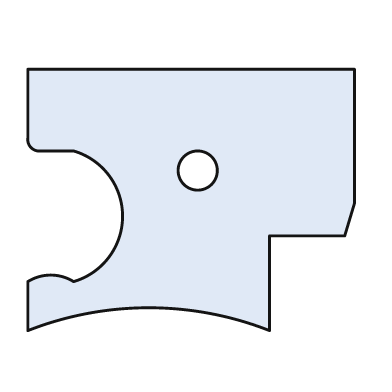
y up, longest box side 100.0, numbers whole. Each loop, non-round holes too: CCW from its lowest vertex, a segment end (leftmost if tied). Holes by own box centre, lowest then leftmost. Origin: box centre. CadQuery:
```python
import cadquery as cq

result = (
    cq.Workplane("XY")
    .moveTo(-50.0, -40.0)
    .threePointArc((-13.0, -33.0), (24.0, -40.0))
    .lineTo(24.0, -11.0)
    .lineTo(47.0, -11.0)
    .lineTo(50.0, -1.0)
    .lineTo(50.0, 40.0)
    .lineTo(-50.0, 40.0)
    .lineTo(-50.0, 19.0)
    .threePointArc((-49.0, 16.0), (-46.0, 15.0))
    .lineTo(-36.0, 15.0)
    .threePointArc((-21.0, -5.0), (-36.0, -25.0))
    .threePointArc((-43.0, -23.0), (-50.0, -25.0))
    .close()
    .moveTo(2.0, 9.0)
    .circle(6.0)
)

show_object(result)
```